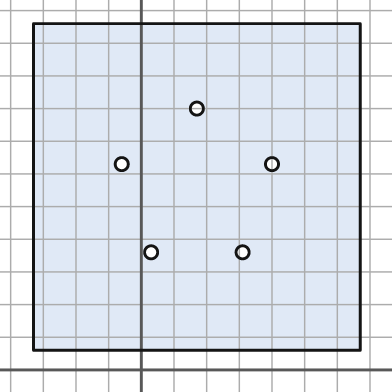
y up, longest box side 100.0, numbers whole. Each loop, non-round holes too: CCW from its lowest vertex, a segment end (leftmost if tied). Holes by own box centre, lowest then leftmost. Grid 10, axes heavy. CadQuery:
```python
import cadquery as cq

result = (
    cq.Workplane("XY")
    .moveTo(-33.0, 6.0)
    .lineTo(67.0, 6.0)
    .lineTo(67.0, 106.0)
    .lineTo(-33.0, 106.0)
    .close()
    .moveTo(3.0, 36.0)
    .circle(2.0)
    .moveTo(31.0, 36.0)
    .circle(2.0)
    .moveTo(-6.0, 63.0)
    .circle(2.0)
    .moveTo(40.0, 63.0)
    .circle(2.0)
    .moveTo(17.0, 80.0)
    .circle(2.0)
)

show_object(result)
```